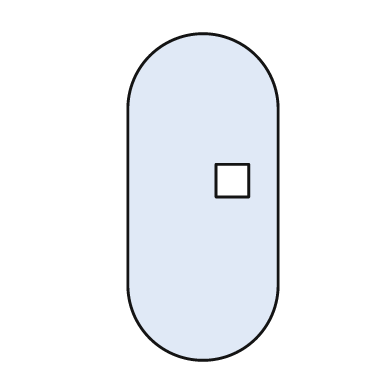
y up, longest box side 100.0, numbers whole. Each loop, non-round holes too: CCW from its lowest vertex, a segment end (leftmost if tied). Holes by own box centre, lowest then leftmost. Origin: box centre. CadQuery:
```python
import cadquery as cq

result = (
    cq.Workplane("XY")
    .moveTo(-23.0, -27.0)
    .threePointArc((0.0, -50.0), (23.0, -27.0))
    .lineTo(23.0, 27.0)
    .threePointArc((0.0, 50.0), (-23.0, 27.0))
    .close()
    .moveTo(4.0, 0.0)
    .lineTo(14.0, 0.0)
    .lineTo(14.0, 10.0)
    .lineTo(4.0, 10.0)
    .close()
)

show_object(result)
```